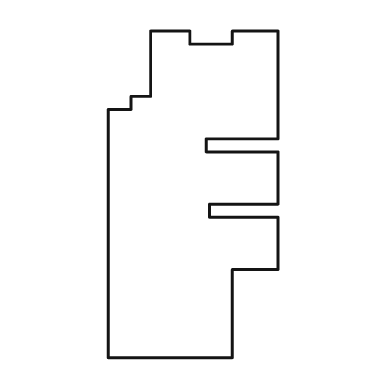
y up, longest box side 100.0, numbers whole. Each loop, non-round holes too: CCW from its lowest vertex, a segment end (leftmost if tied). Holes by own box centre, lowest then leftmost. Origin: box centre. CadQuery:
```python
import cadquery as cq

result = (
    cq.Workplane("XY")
    .moveTo(-26.0, -50.0)
    .lineTo(12.0, -50.0)
    .lineTo(12.0, -23.0)
    .lineTo(26.0, -23.0)
    .lineTo(26.0, -7.0)
    .lineTo(5.0, -7.0)
    .lineTo(5.0, -3.0)
    .lineTo(26.0, -3.0)
    .lineTo(26.0, 13.0)
    .lineTo(4.0, 13.0)
    .lineTo(4.0, 17.0)
    .lineTo(26.0, 17.0)
    .lineTo(26.0, 50.0)
    .lineTo(12.0, 50.0)
    .lineTo(12.0, 46.0)
    .lineTo(-1.0, 46.0)
    .lineTo(-1.0, 50.0)
    .lineTo(-13.0, 50.0)
    .lineTo(-13.0, 30.0)
    .lineTo(-19.0, 30.0)
    .lineTo(-19.0, 26.0)
    .lineTo(-26.0, 26.0)
    .close()
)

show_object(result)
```